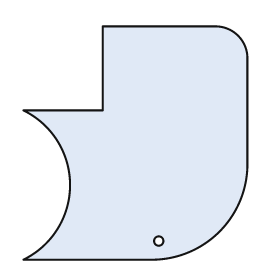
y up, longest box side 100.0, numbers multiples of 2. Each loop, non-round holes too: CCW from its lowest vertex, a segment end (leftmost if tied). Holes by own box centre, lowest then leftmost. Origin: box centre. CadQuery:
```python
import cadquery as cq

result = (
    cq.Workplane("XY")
    .moveTo(-48.0, -50.0)
    .lineTo(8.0, -50.0)
    .threePointArc((36.0, -38.0), (48.0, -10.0))
    .lineTo(48.0, 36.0)
    .threePointArc((44.0, 46.0), (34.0, 50.0))
    .lineTo(-14.0, 50.0)
    .lineTo(-14.0, 14.0)
    .lineTo(-48.0, 14.0)
    .threePointArc((-28.0, -18.0), (-48.0, -50.0))
    .close()
    .moveTo(10.0, -42.0)
    .circle(2.0)
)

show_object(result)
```